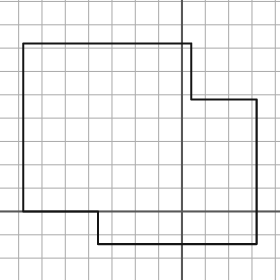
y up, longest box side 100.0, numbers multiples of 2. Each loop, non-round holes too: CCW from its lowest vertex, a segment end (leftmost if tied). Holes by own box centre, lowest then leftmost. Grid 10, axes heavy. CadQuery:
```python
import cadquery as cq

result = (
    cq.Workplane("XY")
    .moveTo(-36.0, -14.0)
    .lineTo(32.0, -14.0)
    .lineTo(32.0, 48.0)
    .lineTo(4.0, 48.0)
    .lineTo(4.0, 72.0)
    .lineTo(-68.0, 72.0)
    .lineTo(-68.0, 0.0)
    .lineTo(-36.0, 0.0)
    .close()
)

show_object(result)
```